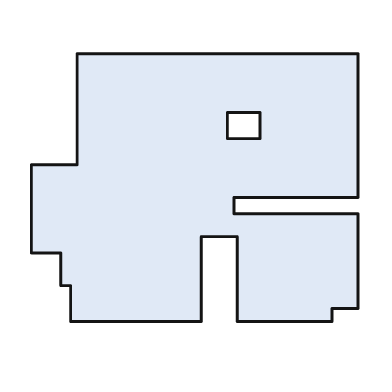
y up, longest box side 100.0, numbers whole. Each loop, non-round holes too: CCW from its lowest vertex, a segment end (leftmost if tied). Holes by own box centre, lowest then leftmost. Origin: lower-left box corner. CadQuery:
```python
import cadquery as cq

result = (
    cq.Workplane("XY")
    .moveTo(12.0, 0.0)
    .lineTo(52.0, 0.0)
    .lineTo(52.0, 26.0)
    .lineTo(63.0, 26.0)
    .lineTo(63.0, 0.0)
    .lineTo(92.0, 0.0)
    .lineTo(92.0, 4.0)
    .lineTo(100.0, 4.0)
    .lineTo(100.0, 33.0)
    .lineTo(62.0, 33.0)
    .lineTo(62.0, 38.0)
    .lineTo(100.0, 38.0)
    .lineTo(100.0, 82.0)
    .lineTo(14.0, 82.0)
    .lineTo(14.0, 48.0)
    .lineTo(0.0, 48.0)
    .lineTo(0.0, 21.0)
    .lineTo(9.0, 21.0)
    .lineTo(9.0, 11.0)
    .lineTo(12.0, 11.0)
    .close()
    .moveTo(60.0, 56.0)
    .lineTo(70.0, 56.0)
    .lineTo(70.0, 64.0)
    .lineTo(60.0, 64.0)
    .close()
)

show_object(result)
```